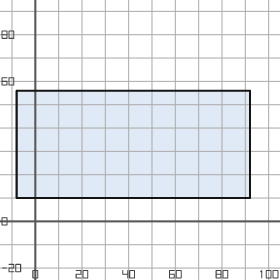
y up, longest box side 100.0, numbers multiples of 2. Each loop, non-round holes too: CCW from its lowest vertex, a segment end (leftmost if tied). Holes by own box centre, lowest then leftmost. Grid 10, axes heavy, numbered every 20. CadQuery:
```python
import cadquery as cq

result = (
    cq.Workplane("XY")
    .moveTo(-8.0, 10.0)
    .lineTo(92.0, 10.0)
    .lineTo(92.0, 56.0)
    .lineTo(-8.0, 56.0)
    .close()
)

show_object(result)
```